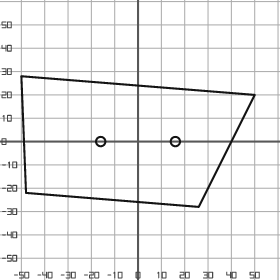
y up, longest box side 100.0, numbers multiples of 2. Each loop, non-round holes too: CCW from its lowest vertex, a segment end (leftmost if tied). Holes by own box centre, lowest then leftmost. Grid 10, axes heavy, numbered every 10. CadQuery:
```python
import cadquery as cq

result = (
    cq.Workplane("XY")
    .moveTo(26.0, -28.0)
    .lineTo(50.0, 20.0)
    .lineTo(-50.0, 28.0)
    .lineTo(-48.0, -22.0)
    .close()
    .moveTo(-16.0, 0.0)
    .circle(2.0)
    .moveTo(16.0, 0.0)
    .circle(2.0)
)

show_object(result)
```